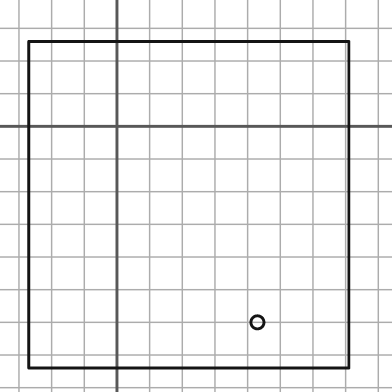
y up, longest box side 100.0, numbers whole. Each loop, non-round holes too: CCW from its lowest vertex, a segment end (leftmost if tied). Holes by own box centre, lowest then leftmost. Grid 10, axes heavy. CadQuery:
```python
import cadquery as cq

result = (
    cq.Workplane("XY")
    .moveTo(-27.0, -74.0)
    .lineTo(71.0, -74.0)
    .lineTo(71.0, 26.0)
    .lineTo(-27.0, 26.0)
    .close()
    .moveTo(43.0, -60.0)
    .circle(2.0)
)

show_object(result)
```